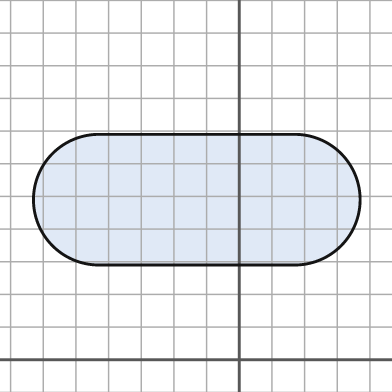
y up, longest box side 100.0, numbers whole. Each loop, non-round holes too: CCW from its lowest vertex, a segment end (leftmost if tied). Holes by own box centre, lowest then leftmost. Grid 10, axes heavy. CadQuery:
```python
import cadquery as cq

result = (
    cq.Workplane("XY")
    .moveTo(-43.0, 29.0)
    .lineTo(17.0, 29.0)
    .threePointArc((37.0, 49.0), (17.0, 69.0))
    .lineTo(-43.0, 69.0)
    .threePointArc((-63.0, 49.0), (-43.0, 29.0))
    .close()
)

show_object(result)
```